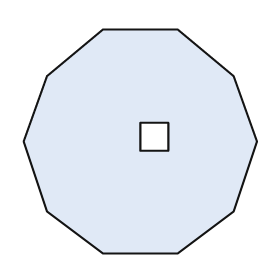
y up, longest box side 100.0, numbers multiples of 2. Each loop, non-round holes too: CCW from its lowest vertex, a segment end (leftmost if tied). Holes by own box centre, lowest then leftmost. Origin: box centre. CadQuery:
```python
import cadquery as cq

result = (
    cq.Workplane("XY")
    .moveTo(-16.0, -48.0)
    .lineTo(16.0, -48.0)
    .lineTo(40.0, -30.0)
    .lineTo(50.0, 0.0)
    .lineTo(40.0, 28.0)
    .lineTo(16.0, 48.0)
    .lineTo(-16.0, 48.0)
    .lineTo(-40.0, 28.0)
    .lineTo(-50.0, 0.0)
    .lineTo(-40.0, -30.0)
    .close()
    .moveTo(0.0, -4.0)
    .lineTo(12.0, -4.0)
    .lineTo(12.0, 8.0)
    .lineTo(0.0, 8.0)
    .close()
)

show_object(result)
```